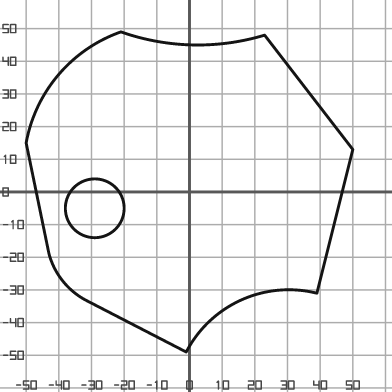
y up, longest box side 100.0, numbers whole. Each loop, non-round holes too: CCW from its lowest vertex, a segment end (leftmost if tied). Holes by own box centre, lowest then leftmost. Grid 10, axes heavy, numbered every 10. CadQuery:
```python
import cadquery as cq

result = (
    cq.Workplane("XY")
    .moveTo(-1.0, -49.0)
    .threePointArc((16.0, -33.0), (39.0, -31.0))
    .lineTo(50.0, 13.0)
    .lineTo(23.0, 48.0)
    .threePointArc((1.0, 45.0), (-21.0, 49.0))
    .threePointArc((-40.0, 36.0), (-50.0, 15.0))
    .lineTo(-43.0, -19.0)
    .threePointArc((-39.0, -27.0), (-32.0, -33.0))
    .close()
    .moveTo(-29.0, -5.0)
    .circle(9.0)
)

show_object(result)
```